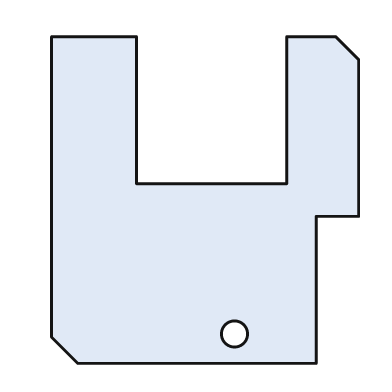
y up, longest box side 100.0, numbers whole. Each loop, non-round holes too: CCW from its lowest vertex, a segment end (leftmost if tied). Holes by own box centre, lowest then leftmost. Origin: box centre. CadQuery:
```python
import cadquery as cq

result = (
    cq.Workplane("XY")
    .moveTo(-39.0, -50.0)
    .lineTo(34.0, -50.0)
    .lineTo(34.0, -5.0)
    .lineTo(47.0, -5.0)
    .lineTo(47.0, 43.0)
    .lineTo(40.0, 50.0)
    .lineTo(25.0, 50.0)
    .lineTo(25.0, 5.0)
    .lineTo(-21.0, 5.0)
    .lineTo(-21.0, 50.0)
    .lineTo(-47.0, 50.0)
    .lineTo(-47.0, -42.0)
    .close()
    .moveTo(9.0, -41.0)
    .circle(4.0)
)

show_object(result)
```